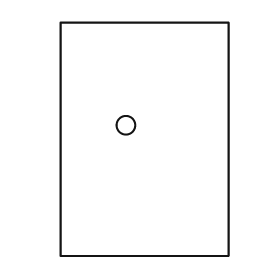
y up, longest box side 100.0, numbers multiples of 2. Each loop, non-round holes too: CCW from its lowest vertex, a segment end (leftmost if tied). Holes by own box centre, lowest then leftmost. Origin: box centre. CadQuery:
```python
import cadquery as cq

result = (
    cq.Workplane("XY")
    .moveTo(-36.0, -50.0)
    .lineTo(36.0, -50.0)
    .lineTo(36.0, 50.0)
    .lineTo(-36.0, 50.0)
    .close()
    .moveTo(-8.0, 6.0)
    .circle(4.0)
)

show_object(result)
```